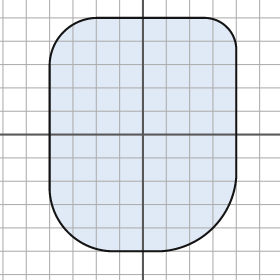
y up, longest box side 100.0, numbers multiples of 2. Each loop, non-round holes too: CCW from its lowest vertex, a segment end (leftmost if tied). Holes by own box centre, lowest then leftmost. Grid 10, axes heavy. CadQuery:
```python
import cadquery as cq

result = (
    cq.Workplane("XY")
    .moveTo(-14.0, -50.0)
    .lineTo(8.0, -50.0)
    .threePointArc((30.0, -40.0), (40.0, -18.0))
    .lineTo(40.0, 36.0)
    .threePointArc((36.0, 46.0), (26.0, 50.0))
    .lineTo(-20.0, 50.0)
    .threePointArc((-34.0, 44.0), (-40.0, 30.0))
    .lineTo(-40.0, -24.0)
    .threePointArc((-32.0, -42.0), (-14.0, -50.0))
    .close()
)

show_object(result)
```